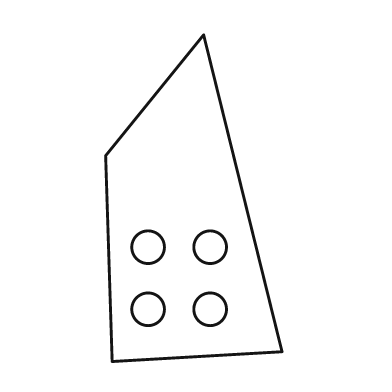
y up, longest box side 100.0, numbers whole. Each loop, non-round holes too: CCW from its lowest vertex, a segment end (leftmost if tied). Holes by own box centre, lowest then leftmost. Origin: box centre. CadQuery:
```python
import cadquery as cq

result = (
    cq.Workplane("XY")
    .moveTo(-25.0, -50.0)
    .lineTo(27.0, -47.0)
    .lineTo(3.0, 50.0)
    .lineTo(-27.0, 13.0)
    .close()
    .moveTo(-14.0, -34.0)
    .circle(5.0)
    .moveTo(5.0, -34.0)
    .circle(5.0)
    .moveTo(-14.0, -15.0)
    .circle(5.0)
    .moveTo(5.0, -15.0)
    .circle(5.0)
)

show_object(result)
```